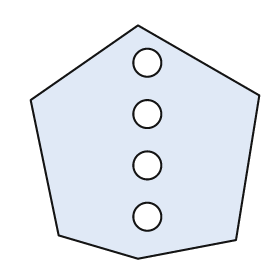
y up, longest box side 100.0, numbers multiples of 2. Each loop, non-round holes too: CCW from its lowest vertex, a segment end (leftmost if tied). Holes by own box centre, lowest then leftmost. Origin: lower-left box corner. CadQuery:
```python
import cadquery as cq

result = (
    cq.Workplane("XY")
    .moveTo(46.0, 0.0)
    .lineTo(88.0, 8.0)
    .lineTo(98.0, 70.0)
    .lineTo(46.0, 100.0)
    .lineTo(0.0, 68.0)
    .lineTo(12.0, 10.0)
    .close()
    .moveTo(50.0, 18.0)
    .circle(6.0)
    .moveTo(50.0, 40.0)
    .circle(6.0)
    .moveTo(50.0, 62.0)
    .circle(6.0)
    .moveTo(50.0, 84.0)
    .circle(6.0)
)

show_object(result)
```